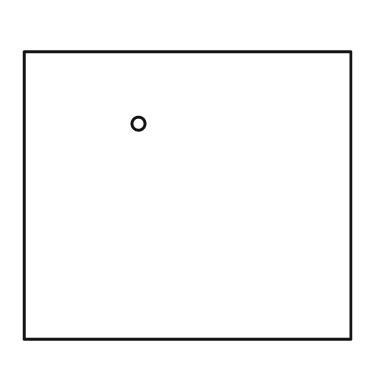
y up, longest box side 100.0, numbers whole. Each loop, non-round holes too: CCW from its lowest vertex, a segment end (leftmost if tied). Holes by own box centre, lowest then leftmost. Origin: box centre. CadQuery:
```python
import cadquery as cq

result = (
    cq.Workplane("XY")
    .moveTo(-50.0, -44.0)
    .lineTo(50.0, -44.0)
    .lineTo(50.0, 44.0)
    .lineTo(-50.0, 44.0)
    .close()
    .moveTo(-15.0, 22.0)
    .circle(2.0)
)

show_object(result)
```